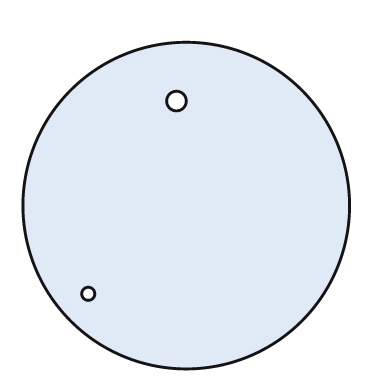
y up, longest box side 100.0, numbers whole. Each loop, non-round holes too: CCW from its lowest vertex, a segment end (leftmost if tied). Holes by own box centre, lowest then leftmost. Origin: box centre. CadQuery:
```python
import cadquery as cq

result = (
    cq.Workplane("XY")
    .moveTo(0.0, 0.0)
    .circle(50.0)
    .moveTo(-30.0, -27.0)
    .circle(2.0)
    .moveTo(-3.0, 32.0)
    .circle(3.0)
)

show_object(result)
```